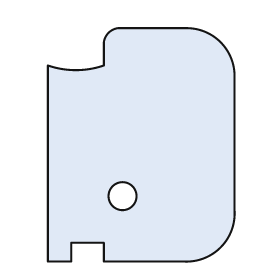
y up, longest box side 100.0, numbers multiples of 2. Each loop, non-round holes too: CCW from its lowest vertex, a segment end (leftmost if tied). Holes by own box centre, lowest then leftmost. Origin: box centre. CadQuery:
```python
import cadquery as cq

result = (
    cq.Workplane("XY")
    .moveTo(-40.0, -50.0)
    .lineTo(-30.0, -50.0)
    .lineTo(-30.0, -42.0)
    .lineTo(-16.0, -42.0)
    .lineTo(-16.0, -50.0)
    .lineTo(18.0, -50.0)
    .threePointArc((34.0, -44.0), (40.0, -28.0))
    .lineTo(40.0, 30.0)
    .threePointArc((34.0, 44.0), (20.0, 50.0))
    .lineTo(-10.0, 50.0)
    .threePointArc((-14.0, 48.0), (-16.0, 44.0))
    .lineTo(-16.0, 34.0)
    .threePointArc((-28.0, 32.0), (-40.0, 34.0))
    .close()
    .moveTo(-8.0, -22.0)
    .circle(6.0)
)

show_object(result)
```